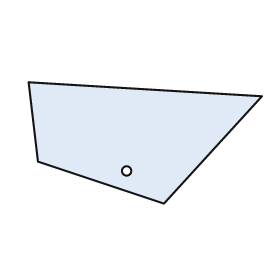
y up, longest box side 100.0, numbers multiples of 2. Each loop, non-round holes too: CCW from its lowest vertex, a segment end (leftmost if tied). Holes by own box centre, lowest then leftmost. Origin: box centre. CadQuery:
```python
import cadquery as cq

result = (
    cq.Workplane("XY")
    .moveTo(8.0, -26.0)
    .lineTo(50.0, 20.0)
    .lineTo(-50.0, 26.0)
    .lineTo(-46.0, -8.0)
    .close()
    .moveTo(-8.0, -12.0)
    .circle(2.0)
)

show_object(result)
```